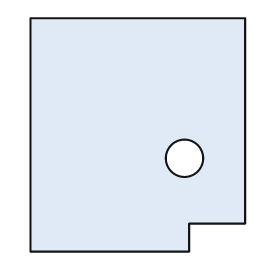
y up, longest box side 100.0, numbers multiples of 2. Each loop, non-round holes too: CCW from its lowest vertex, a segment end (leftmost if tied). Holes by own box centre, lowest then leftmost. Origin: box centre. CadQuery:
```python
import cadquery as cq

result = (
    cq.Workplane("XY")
    .moveTo(-46.0, -50.0)
    .lineTo(22.0, -50.0)
    .lineTo(22.0, -38.0)
    .lineTo(46.0, -38.0)
    .lineTo(46.0, 50.0)
    .lineTo(-46.0, 50.0)
    .close()
    .moveTo(20.0, -10.0)
    .circle(8.0)
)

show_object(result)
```